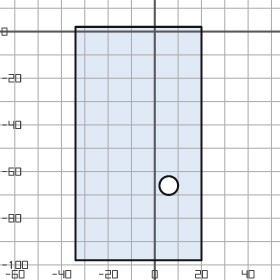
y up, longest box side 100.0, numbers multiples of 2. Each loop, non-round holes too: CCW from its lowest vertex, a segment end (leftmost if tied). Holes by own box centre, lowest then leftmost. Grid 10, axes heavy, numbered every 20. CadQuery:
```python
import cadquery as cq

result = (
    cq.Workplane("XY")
    .moveTo(-34.0, -98.0)
    .lineTo(20.0, -98.0)
    .lineTo(20.0, 2.0)
    .lineTo(-34.0, 2.0)
    .close()
    .moveTo(6.0, -66.0)
    .circle(4.0)
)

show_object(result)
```